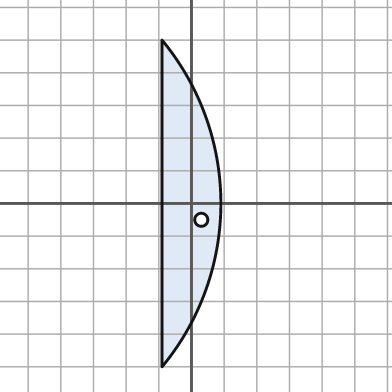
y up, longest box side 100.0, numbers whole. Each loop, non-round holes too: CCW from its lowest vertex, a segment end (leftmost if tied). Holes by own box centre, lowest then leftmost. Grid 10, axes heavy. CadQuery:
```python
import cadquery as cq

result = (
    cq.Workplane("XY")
    .moveTo(-9.0, -50.0)
    .threePointArc((9.0, 0.0), (-9.0, 50.0))
    .close()
    .moveTo(3.0, -5.0)
    .circle(2.0)
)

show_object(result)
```